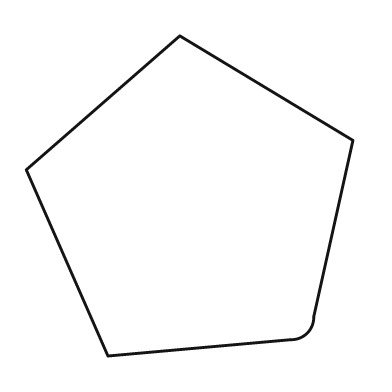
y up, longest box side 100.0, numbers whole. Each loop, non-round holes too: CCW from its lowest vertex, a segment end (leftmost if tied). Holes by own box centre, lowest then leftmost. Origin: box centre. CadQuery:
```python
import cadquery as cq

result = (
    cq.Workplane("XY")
    .moveTo(-25.0, -49.0)
    .lineTo(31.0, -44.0)
    .threePointArc((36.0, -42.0), (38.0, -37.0))
    .lineTo(50.0, 17.0)
    .lineTo(-3.0, 49.0)
    .lineTo(-50.0, 8.0)
    .close()
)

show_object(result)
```